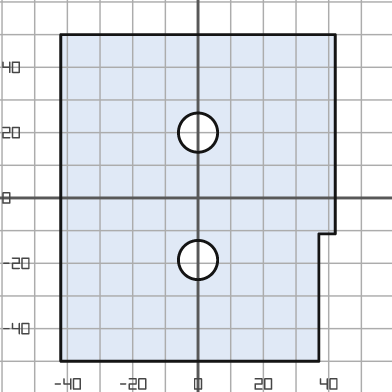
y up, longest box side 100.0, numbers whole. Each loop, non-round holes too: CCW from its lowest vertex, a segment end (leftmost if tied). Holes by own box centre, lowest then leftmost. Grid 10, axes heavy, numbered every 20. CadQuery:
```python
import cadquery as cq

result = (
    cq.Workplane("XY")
    .moveTo(-42.0, -50.0)
    .lineTo(37.0, -50.0)
    .lineTo(37.0, -11.0)
    .lineTo(42.0, -11.0)
    .lineTo(42.0, 50.0)
    .lineTo(-42.0, 50.0)
    .close()
    .moveTo(0.0, -19.0)
    .circle(6.0)
    .moveTo(0.0, 20.0)
    .circle(6.0)
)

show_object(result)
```